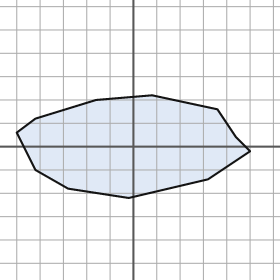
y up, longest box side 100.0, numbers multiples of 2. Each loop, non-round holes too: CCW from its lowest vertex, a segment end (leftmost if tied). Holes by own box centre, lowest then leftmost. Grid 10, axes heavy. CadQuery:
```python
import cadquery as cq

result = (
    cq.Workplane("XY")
    .moveTo(-2.0, -22.0)
    .lineTo(32.0, -14.0)
    .lineTo(50.0, -2.0)
    .lineTo(44.0, 4.0)
    .lineTo(36.0, 16.0)
    .lineTo(8.0, 22.0)
    .lineTo(-16.0, 20.0)
    .lineTo(-42.0, 12.0)
    .lineTo(-50.0, 6.0)
    .lineTo(-42.0, -10.0)
    .lineTo(-28.0, -18.0)
    .close()
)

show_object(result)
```